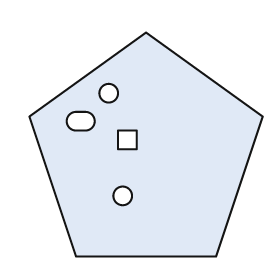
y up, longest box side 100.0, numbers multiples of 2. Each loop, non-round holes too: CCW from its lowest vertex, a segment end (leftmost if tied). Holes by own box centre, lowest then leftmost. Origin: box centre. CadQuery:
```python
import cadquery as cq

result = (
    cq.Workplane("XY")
    .moveTo(-30.0, -48.0)
    .lineTo(30.0, -48.0)
    .lineTo(50.0, 12.0)
    .lineTo(0.0, 48.0)
    .lineTo(-50.0, 12.0)
    .close()
    .moveTo(-10.0, -22.0)
    .circle(4.0)
    .moveTo(-12.0, -2.0)
    .lineTo(-4.0, -2.0)
    .lineTo(-4.0, 6.0)
    .lineTo(-12.0, 6.0)
    .close()
    .moveTo(-30.0, 6.0)
    .lineTo(-26.0, 6.0)
    .threePointArc((-22.0, 10.0), (-26.0, 14.0))
    .lineTo(-30.0, 14.0)
    .threePointArc((-34.0, 10.0), (-30.0, 6.0))
    .close()
    .moveTo(-16.0, 22.0)
    .circle(4.0)
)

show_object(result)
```